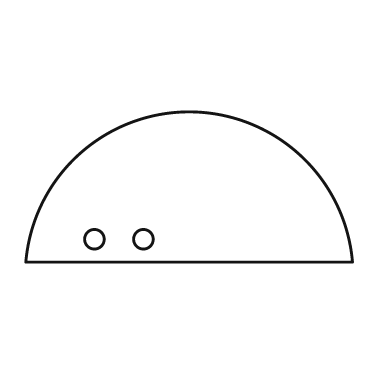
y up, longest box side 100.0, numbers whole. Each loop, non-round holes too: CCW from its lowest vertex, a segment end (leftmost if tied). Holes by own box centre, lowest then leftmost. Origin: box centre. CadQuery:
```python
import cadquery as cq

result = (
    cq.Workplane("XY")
    .moveTo(-50.0, -23.0)
    .lineTo(50.0, -23.0)
    .threePointArc((0.0, 23.0), (-50.0, -23.0))
    .close()
    .moveTo(-29.0, -16.0)
    .circle(3.0)
    .moveTo(-14.0, -16.0)
    .circle(3.0)
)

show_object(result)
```